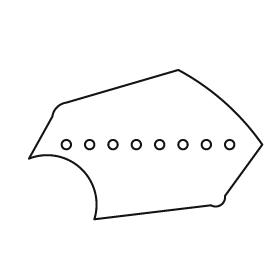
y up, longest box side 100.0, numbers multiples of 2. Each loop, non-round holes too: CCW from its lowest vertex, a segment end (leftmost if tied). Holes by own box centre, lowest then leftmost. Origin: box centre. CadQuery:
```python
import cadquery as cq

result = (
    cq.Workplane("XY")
    .moveTo(-22.0, -32.0)
    .lineTo(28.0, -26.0)
    .threePointArc((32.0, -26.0), (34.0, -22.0))
    .lineTo(50.0, 0.0)
    .threePointArc((34.0, 18.0), (14.0, 32.0))
    .lineTo(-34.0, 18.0)
    .threePointArc((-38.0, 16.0), (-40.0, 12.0))
    .lineTo(-50.0, -6.0)
    .threePointArc((-28.0, -10.0), (-22.0, -32.0))
    .close()
    .moveTo(-34.0, 0.0)
    .circle(2.0)
    .moveTo(-24.0, 0.0)
    .circle(2.0)
    .moveTo(-14.0, 0.0)
    .circle(2.0)
    .moveTo(-4.0, 0.0)
    .circle(2.0)
    .moveTo(6.0, 0.0)
    .circle(2.0)
    .moveTo(16.0, 0.0)
    .circle(2.0)
    .moveTo(26.0, 0.0)
    .circle(2.0)
    .moveTo(36.0, 0.0)
    .circle(2.0)
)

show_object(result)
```